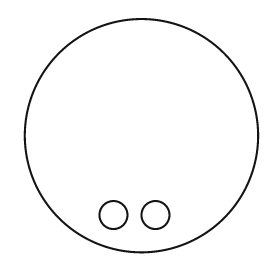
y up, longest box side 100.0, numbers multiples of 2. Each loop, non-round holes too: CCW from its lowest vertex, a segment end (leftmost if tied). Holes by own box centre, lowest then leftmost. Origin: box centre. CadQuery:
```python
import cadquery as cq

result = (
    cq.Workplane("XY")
    .moveTo(0.0, 0.0)
    .circle(50.0)
    .moveTo(-12.0, -34.0)
    .circle(6.0)
    .moveTo(6.0, -34.0)
    .circle(6.0)
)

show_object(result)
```